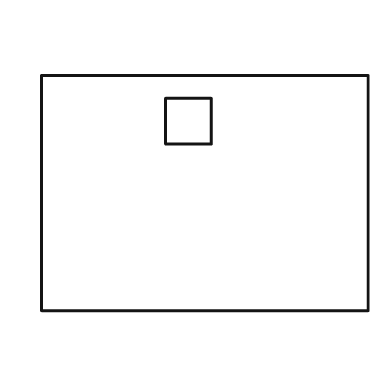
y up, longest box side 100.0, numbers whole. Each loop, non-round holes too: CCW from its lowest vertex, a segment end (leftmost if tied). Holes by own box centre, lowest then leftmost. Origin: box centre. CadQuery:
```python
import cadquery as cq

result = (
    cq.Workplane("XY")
    .moveTo(-50.0, -36.0)
    .lineTo(50.0, -36.0)
    .lineTo(50.0, 36.0)
    .lineTo(-50.0, 36.0)
    .close()
    .moveTo(-12.0, 15.0)
    .lineTo(2.0, 15.0)
    .lineTo(2.0, 29.0)
    .lineTo(-12.0, 29.0)
    .close()
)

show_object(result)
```